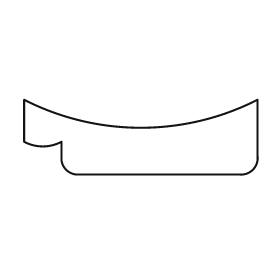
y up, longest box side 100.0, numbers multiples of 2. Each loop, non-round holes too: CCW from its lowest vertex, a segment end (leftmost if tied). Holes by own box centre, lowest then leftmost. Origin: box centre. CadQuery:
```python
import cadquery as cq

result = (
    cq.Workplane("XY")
    .moveTo(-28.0, -16.0)
    .lineTo(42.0, -16.0)
    .threePointArc((48.0, -14.0), (50.0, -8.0))
    .lineTo(50.0, 16.0)
    .threePointArc((0.0, 4.0), (-50.0, 16.0))
    .lineTo(-50.0, -2.0)
    .threePointArc((-42.0, -4.0), (-34.0, -2.0))
    .lineTo(-34.0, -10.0)
    .threePointArc((-32.0, -14.0), (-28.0, -16.0))
    .close()
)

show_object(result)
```